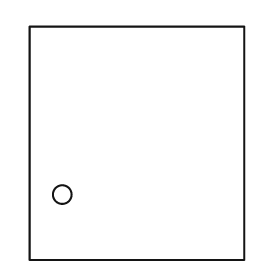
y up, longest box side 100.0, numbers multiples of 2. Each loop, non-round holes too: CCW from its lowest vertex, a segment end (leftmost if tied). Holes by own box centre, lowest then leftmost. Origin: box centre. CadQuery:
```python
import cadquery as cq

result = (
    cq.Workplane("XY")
    .moveTo(-46.0, -50.0)
    .lineTo(46.0, -50.0)
    .lineTo(46.0, 50.0)
    .lineTo(-46.0, 50.0)
    .close()
    .moveTo(-32.0, -22.0)
    .circle(4.0)
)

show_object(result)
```